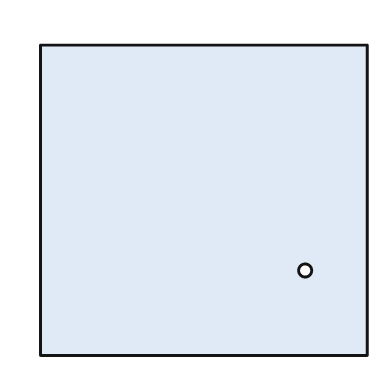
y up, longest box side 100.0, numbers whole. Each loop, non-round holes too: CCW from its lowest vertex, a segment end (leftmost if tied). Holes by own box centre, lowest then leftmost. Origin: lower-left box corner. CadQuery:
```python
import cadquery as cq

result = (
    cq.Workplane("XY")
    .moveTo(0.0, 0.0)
    .lineTo(100.0, 0.0)
    .lineTo(100.0, 95.0)
    .lineTo(0.0, 95.0)
    .close()
    .moveTo(81.0, 26.0)
    .circle(2.0)
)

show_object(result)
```